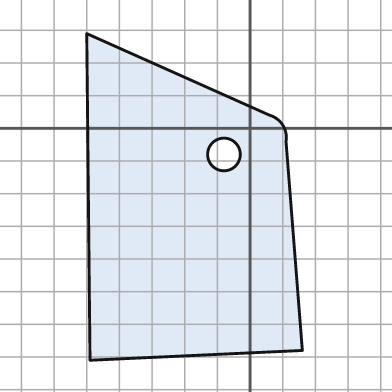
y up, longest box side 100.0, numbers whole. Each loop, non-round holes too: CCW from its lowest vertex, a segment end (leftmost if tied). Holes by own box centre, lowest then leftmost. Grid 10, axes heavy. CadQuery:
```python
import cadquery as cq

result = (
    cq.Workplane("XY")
    .moveTo(-49.0, -71.0)
    .lineTo(16.0, -68.0)
    .lineTo(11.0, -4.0)
    .threePointArc((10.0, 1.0), (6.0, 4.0))
    .lineTo(-50.0, 29.0)
    .close()
    .moveTo(-8.0, -8.0)
    .circle(5.0)
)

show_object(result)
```